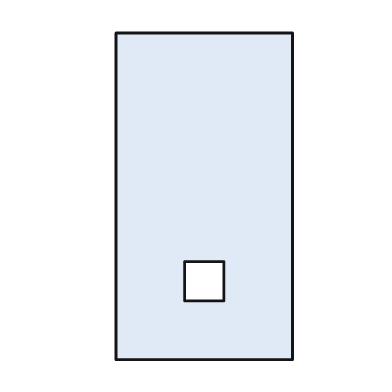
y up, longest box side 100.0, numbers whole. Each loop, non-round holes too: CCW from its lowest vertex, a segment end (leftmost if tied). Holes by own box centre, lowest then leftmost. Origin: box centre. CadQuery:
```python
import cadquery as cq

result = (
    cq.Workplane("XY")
    .moveTo(-27.0, -50.0)
    .lineTo(27.0, -50.0)
    .lineTo(27.0, 50.0)
    .lineTo(-27.0, 50.0)
    .close()
    .moveTo(-6.0, -32.0)
    .lineTo(6.0, -32.0)
    .lineTo(6.0, -20.0)
    .lineTo(-6.0, -20.0)
    .close()
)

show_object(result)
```